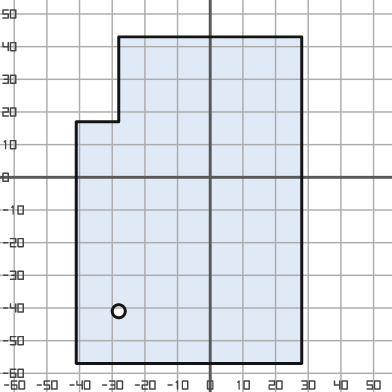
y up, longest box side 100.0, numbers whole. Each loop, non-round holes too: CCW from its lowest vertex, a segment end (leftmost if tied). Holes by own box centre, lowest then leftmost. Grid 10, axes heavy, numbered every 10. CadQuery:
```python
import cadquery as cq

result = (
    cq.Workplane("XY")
    .moveTo(-41.0, -57.0)
    .lineTo(28.0, -57.0)
    .lineTo(28.0, 43.0)
    .lineTo(-28.0, 43.0)
    .lineTo(-28.0, 17.0)
    .lineTo(-41.0, 17.0)
    .close()
    .moveTo(-28.0, -41.0)
    .circle(2.0)
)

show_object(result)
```